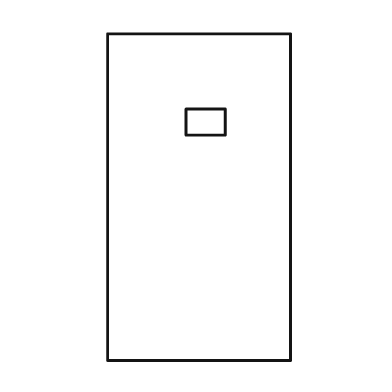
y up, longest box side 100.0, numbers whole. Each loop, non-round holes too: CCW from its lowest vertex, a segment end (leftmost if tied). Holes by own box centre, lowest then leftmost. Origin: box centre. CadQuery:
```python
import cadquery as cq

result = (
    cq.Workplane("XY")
    .moveTo(-28.0, -50.0)
    .lineTo(28.0, -50.0)
    .lineTo(28.0, 50.0)
    .lineTo(-28.0, 50.0)
    .close()
    .moveTo(-4.0, 19.0)
    .lineTo(8.0, 19.0)
    .lineTo(8.0, 27.0)
    .lineTo(-4.0, 27.0)
    .close()
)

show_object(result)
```